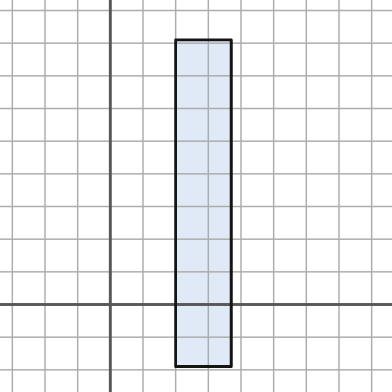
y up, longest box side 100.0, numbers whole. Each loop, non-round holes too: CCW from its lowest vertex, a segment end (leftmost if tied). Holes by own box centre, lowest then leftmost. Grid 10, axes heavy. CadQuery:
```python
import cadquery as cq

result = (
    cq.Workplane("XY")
    .moveTo(20.0, -19.0)
    .lineTo(37.0, -19.0)
    .lineTo(37.0, 81.0)
    .lineTo(20.0, 81.0)
    .close()
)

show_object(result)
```